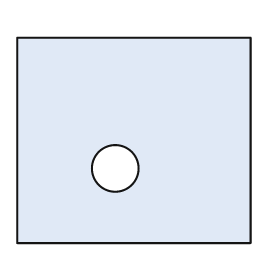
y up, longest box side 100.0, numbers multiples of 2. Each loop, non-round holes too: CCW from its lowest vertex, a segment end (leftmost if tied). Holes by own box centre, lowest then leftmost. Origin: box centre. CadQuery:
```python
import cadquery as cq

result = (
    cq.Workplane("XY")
    .moveTo(-50.0, -44.0)
    .lineTo(50.0, -44.0)
    .lineTo(50.0, 44.0)
    .lineTo(-50.0, 44.0)
    .close()
    .moveTo(-8.0, -12.0)
    .circle(10.0)
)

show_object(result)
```